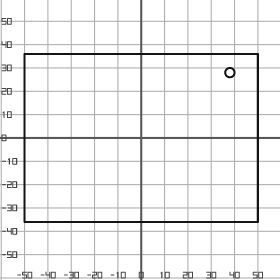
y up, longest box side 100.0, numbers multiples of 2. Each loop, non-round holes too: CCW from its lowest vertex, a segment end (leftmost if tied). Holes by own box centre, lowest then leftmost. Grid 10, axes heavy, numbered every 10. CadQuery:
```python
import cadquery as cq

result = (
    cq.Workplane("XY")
    .moveTo(-50.0, -36.0)
    .lineTo(50.0, -36.0)
    .lineTo(50.0, 36.0)
    .lineTo(-50.0, 36.0)
    .close()
    .moveTo(38.0, 28.0)
    .circle(2.0)
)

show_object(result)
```